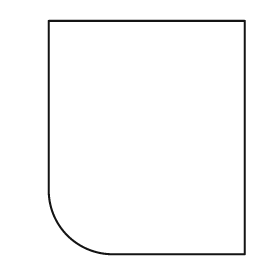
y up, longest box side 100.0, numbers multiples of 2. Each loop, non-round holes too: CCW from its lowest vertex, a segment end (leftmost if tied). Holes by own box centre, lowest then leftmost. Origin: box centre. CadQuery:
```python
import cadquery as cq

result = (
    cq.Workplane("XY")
    .moveTo(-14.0, -50.0)
    .lineTo(42.0, -50.0)
    .lineTo(42.0, 50.0)
    .lineTo(-42.0, 50.0)
    .lineTo(-42.0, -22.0)
    .threePointArc((-34.0, -42.0), (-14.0, -50.0))
    .close()
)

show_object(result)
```